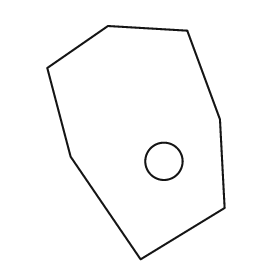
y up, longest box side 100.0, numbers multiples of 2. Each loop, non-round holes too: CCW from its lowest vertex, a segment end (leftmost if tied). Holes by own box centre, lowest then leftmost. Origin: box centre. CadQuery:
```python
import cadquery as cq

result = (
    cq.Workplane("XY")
    .moveTo(2.0, -50.0)
    .lineTo(38.0, -28.0)
    .lineTo(36.0, 10.0)
    .lineTo(22.0, 48.0)
    .lineTo(-12.0, 50.0)
    .lineTo(-38.0, 32.0)
    .lineTo(-28.0, -6.0)
    .close()
    .moveTo(12.0, -8.0)
    .circle(8.0)
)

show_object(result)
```